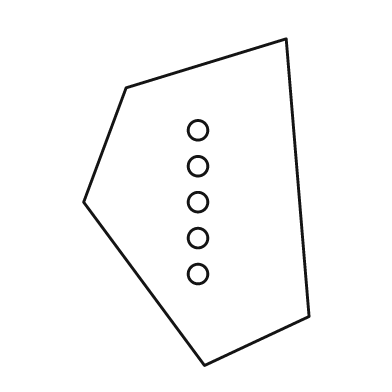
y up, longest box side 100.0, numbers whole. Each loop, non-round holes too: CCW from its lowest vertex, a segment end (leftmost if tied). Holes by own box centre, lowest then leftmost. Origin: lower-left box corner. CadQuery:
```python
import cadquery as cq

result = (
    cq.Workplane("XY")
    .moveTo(37.0, 0.0)
    .lineTo(69.0, 15.0)
    .lineTo(62.0, 100.0)
    .lineTo(13.0, 85.0)
    .lineTo(0.0, 50.0)
    .close()
    .moveTo(35.0, 28.0)
    .circle(3.0)
    .moveTo(35.0, 39.0)
    .circle(3.0)
    .moveTo(35.0, 50.0)
    .circle(3.0)
    .moveTo(35.0, 61.0)
    .circle(3.0)
    .moveTo(35.0, 72.0)
    .circle(3.0)
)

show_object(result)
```